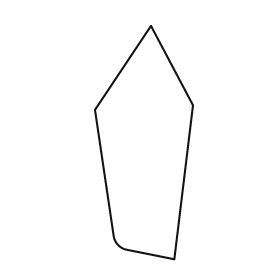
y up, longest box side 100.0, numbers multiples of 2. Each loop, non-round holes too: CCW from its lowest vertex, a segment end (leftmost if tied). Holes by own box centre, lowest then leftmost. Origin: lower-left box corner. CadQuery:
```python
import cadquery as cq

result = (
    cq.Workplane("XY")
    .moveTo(34.0, 0.0)
    .lineTo(42.0, 66.0)
    .lineTo(24.0, 100.0)
    .lineTo(0.0, 64.0)
    .lineTo(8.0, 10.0)
    .threePointArc((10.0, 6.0), (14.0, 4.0))
    .close()
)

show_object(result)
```